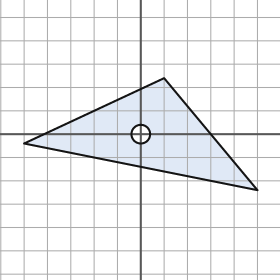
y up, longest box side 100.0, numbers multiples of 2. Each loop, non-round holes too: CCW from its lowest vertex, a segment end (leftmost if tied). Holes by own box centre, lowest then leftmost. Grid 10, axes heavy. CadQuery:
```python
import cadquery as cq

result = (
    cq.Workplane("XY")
    .moveTo(50.0, -24.0)
    .lineTo(10.0, 24.0)
    .lineTo(-50.0, -4.0)
    .close()
    .moveTo(0.0, 0.0)
    .circle(4.0)
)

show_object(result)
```